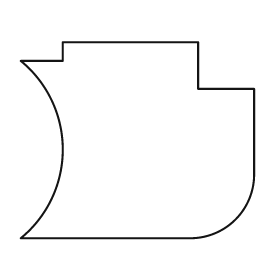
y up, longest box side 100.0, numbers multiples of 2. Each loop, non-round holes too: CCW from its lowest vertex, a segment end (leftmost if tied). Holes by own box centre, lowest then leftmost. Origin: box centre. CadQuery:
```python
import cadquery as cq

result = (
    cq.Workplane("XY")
    .moveTo(-50.0, -42.0)
    .lineTo(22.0, -42.0)
    .threePointArc((42.0, -34.0), (50.0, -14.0))
    .lineTo(50.0, 22.0)
    .lineTo(26.0, 22.0)
    .lineTo(26.0, 42.0)
    .lineTo(-32.0, 42.0)
    .lineTo(-32.0, 34.0)
    .lineTo(-50.0, 34.0)
    .threePointArc((-32.0, -4.0), (-50.0, -42.0))
    .close()
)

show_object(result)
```